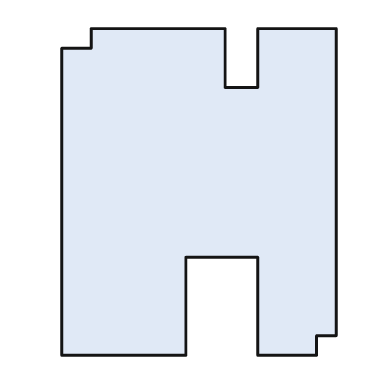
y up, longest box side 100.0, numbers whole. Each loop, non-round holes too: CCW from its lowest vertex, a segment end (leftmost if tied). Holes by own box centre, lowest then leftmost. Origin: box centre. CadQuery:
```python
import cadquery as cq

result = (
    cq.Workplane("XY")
    .moveTo(-42.0, -50.0)
    .lineTo(-4.0, -50.0)
    .lineTo(-4.0, -20.0)
    .lineTo(18.0, -20.0)
    .lineTo(18.0, -50.0)
    .lineTo(36.0, -50.0)
    .lineTo(36.0, -44.0)
    .lineTo(42.0, -44.0)
    .lineTo(42.0, 50.0)
    .lineTo(18.0, 50.0)
    .lineTo(18.0, 32.0)
    .lineTo(8.0, 32.0)
    .lineTo(8.0, 50.0)
    .lineTo(-33.0, 50.0)
    .lineTo(-33.0, 44.0)
    .lineTo(-42.0, 44.0)
    .close()
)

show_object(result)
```